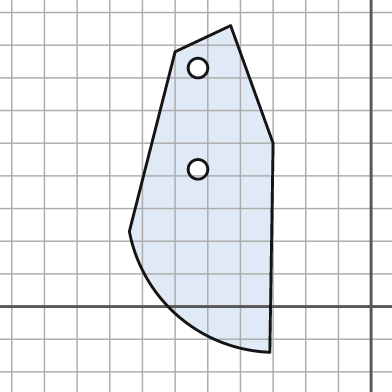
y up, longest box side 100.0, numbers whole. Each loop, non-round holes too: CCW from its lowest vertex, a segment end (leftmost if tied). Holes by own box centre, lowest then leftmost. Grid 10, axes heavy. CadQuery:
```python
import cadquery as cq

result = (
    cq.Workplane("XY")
    .moveTo(-31.0, -14.0)
    .lineTo(-30.0, 50.0)
    .lineTo(-43.0, 86.0)
    .lineTo(-60.0, 78.0)
    .lineTo(-74.0, 23.0)
    .threePointArc((-59.0, -3.0), (-31.0, -14.0))
    .close()
    .moveTo(-53.0, 42.0)
    .circle(3.0)
    .moveTo(-53.0, 73.0)
    .circle(3.0)
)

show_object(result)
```